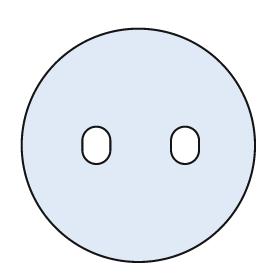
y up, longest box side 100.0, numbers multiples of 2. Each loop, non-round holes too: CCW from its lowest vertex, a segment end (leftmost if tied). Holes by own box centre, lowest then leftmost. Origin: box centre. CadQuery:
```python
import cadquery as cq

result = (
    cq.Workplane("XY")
    .moveTo(0.0, 0.0)
    .circle(50.0)
    .moveTo(-24.0, -2.0)
    .threePointArc((-18.0, -8.0), (-12.0, -2.0))
    .lineTo(-12.0, 2.0)
    .threePointArc((-18.0, 8.0), (-24.0, 2.0))
    .close()
    .moveTo(14.0, -2.0)
    .threePointArc((20.0, -8.0), (26.0, -2.0))
    .lineTo(26.0, 2.0)
    .threePointArc((20.0, 8.0), (14.0, 2.0))
    .close()
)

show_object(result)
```